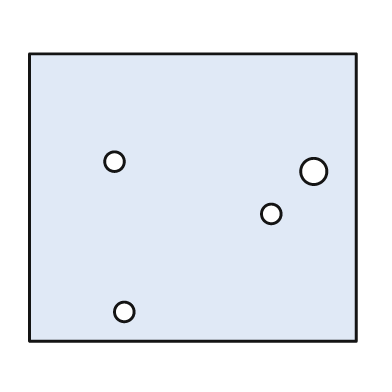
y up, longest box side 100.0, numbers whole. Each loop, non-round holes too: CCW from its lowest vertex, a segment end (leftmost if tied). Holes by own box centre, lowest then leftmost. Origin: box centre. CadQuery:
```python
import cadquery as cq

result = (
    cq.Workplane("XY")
    .moveTo(-50.0, -44.0)
    .lineTo(50.0, -44.0)
    .lineTo(50.0, 44.0)
    .lineTo(-50.0, 44.0)
    .close()
    .moveTo(-21.0, -35.0)
    .circle(3.0)
    .moveTo(24.0, -5.0)
    .circle(3.0)
    .moveTo(37.0, 8.0)
    .circle(4.0)
    .moveTo(-24.0, 11.0)
    .circle(3.0)
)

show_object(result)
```